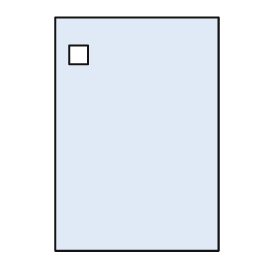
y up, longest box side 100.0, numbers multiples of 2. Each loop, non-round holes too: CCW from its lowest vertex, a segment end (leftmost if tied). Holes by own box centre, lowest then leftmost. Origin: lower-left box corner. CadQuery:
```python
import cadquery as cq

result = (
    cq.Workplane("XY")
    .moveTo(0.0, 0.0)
    .lineTo(70.0, 0.0)
    .lineTo(70.0, 100.0)
    .lineTo(0.0, 100.0)
    .close()
    .moveTo(6.0, 80.0)
    .lineTo(14.0, 80.0)
    .lineTo(14.0, 88.0)
    .lineTo(6.0, 88.0)
    .close()
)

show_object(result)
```